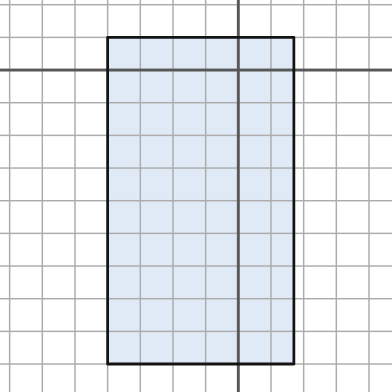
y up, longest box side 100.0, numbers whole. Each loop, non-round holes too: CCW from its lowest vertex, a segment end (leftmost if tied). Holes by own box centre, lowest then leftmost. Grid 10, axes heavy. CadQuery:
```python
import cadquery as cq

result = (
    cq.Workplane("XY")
    .moveTo(-40.0, -90.0)
    .lineTo(17.0, -90.0)
    .lineTo(17.0, 10.0)
    .lineTo(-40.0, 10.0)
    .close()
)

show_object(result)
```